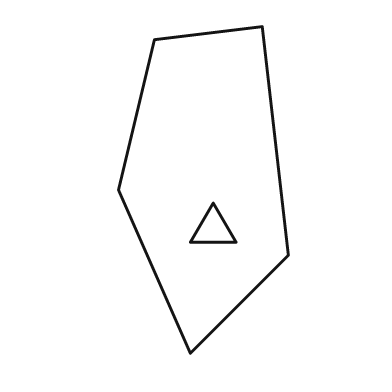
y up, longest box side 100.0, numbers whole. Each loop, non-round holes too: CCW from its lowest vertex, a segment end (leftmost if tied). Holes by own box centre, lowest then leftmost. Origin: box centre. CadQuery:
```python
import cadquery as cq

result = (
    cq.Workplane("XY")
    .moveTo(-4.0, -50.0)
    .lineTo(26.0, -20.0)
    .lineTo(18.0, 50.0)
    .lineTo(-15.0, 46.0)
    .lineTo(-26.0, 0.0)
    .close()
    .moveTo(-4.0, -16.0)
    .lineTo(10.0, -16.0)
    .lineTo(3.0, -4.0)
    .close()
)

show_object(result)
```